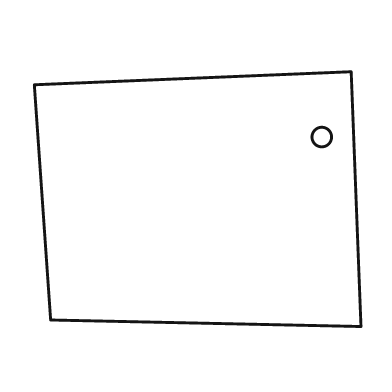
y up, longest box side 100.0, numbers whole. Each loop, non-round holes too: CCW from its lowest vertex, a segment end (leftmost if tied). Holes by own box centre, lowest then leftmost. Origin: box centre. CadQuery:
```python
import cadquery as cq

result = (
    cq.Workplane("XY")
    .moveTo(50.0, -39.0)
    .lineTo(47.0, 39.0)
    .lineTo(-50.0, 35.0)
    .lineTo(-45.0, -37.0)
    .close()
    .moveTo(38.0, 19.0)
    .circle(3.0)
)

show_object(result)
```